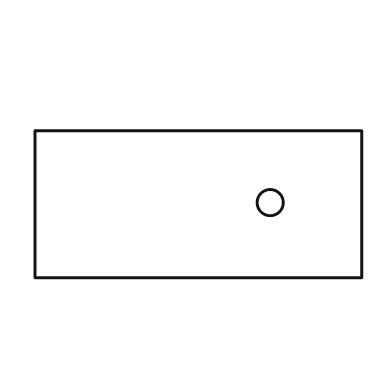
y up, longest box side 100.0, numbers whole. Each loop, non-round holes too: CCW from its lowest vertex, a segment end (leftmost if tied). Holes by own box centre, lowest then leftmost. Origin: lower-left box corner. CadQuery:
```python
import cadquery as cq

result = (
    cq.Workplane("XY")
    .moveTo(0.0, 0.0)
    .lineTo(100.0, 0.0)
    .lineTo(100.0, 45.0)
    .lineTo(0.0, 45.0)
    .close()
    .moveTo(72.0, 23.0)
    .circle(4.0)
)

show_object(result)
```